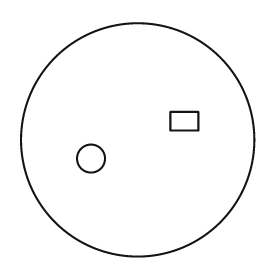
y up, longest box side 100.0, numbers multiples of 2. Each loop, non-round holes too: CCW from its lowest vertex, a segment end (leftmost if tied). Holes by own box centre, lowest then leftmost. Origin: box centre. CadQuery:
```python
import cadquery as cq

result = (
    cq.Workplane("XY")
    .moveTo(0.0, 0.0)
    .circle(50.0)
    .moveTo(-20.0, -8.0)
    .circle(6.0)
    .moveTo(14.0, 4.0)
    .lineTo(26.0, 4.0)
    .lineTo(26.0, 12.0)
    .lineTo(14.0, 12.0)
    .close()
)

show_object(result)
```